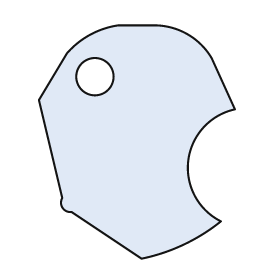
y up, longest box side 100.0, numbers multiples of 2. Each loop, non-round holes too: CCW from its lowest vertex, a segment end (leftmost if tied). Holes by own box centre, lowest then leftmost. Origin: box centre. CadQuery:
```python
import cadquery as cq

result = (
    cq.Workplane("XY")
    .moveTo(2.0, -50.0)
    .threePointArc((20.0, -44.0), (36.0, -34.0))
    .threePointArc((22.0, -8.0), (42.0, 14.0))
    .lineTo(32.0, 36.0)
    .threePointArc((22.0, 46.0), (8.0, 50.0))
    .lineTo(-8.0, 50.0)
    .threePointArc((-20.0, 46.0), (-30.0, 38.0))
    .lineTo(-42.0, 18.0)
    .lineTo(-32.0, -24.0)
    .threePointArc((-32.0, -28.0), (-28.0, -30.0))
    .close()
    .moveTo(-18.0, 28.0)
    .circle(8.0)
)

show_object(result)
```